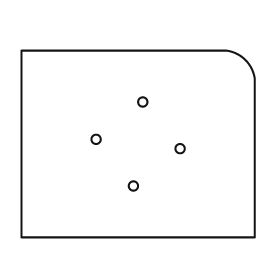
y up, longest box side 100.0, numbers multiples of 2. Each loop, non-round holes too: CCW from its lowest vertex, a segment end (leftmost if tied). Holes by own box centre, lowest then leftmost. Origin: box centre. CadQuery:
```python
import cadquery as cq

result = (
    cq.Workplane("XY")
    .moveTo(-50.0, -40.0)
    .lineTo(50.0, -40.0)
    .lineTo(50.0, 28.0)
    .threePointArc((46.0, 36.0), (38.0, 40.0))
    .lineTo(-50.0, 40.0)
    .close()
    .moveTo(-2.0, -18.0)
    .circle(2.0)
    .moveTo(18.0, -2.0)
    .circle(2.0)
    .moveTo(-18.0, 2.0)
    .circle(2.0)
    .moveTo(2.0, 18.0)
    .circle(2.0)
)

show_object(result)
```